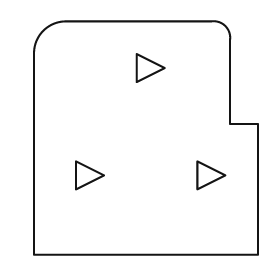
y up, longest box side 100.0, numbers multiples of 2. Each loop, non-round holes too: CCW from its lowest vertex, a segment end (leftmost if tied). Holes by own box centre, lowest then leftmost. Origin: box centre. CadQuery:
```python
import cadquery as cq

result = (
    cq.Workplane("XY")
    .moveTo(-48.0, -50.0)
    .lineTo(48.0, -50.0)
    .lineTo(48.0, 6.0)
    .lineTo(36.0, 6.0)
    .lineTo(36.0, 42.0)
    .threePointArc((34.0, 48.0), (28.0, 50.0))
    .lineTo(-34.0, 50.0)
    .threePointArc((-44.0, 46.0), (-48.0, 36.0))
    .close()
    .moveTo(-30.0, -22.0)
    .lineTo(-18.0, -16.0)
    .lineTo(-30.0, -10.0)
    .close()
    .moveTo(22.0, -22.0)
    .lineTo(34.0, -16.0)
    .lineTo(22.0, -10.0)
    .close()
    .moveTo(-4.0, 24.0)
    .lineTo(8.0, 30.0)
    .lineTo(-4.0, 36.0)
    .close()
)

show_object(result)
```